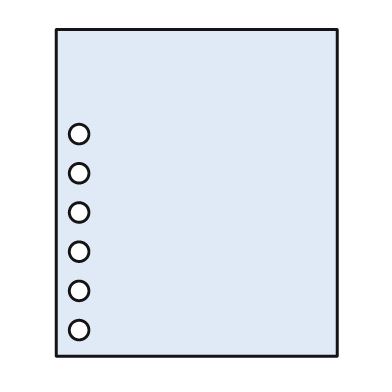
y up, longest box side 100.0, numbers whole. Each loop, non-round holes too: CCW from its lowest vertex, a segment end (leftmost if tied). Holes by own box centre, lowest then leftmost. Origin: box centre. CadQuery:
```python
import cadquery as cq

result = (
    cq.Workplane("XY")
    .moveTo(-43.0, -50.0)
    .lineTo(43.0, -50.0)
    .lineTo(43.0, 50.0)
    .lineTo(-43.0, 50.0)
    .close()
    .moveTo(-36.0, -42.0)
    .circle(3.0)
    .moveTo(-36.0, -30.0)
    .circle(3.0)
    .moveTo(-36.0, -18.0)
    .circle(3.0)
    .moveTo(-36.0, -6.0)
    .circle(3.0)
    .moveTo(-36.0, 6.0)
    .circle(3.0)
    .moveTo(-36.0, 18.0)
    .circle(3.0)
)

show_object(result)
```